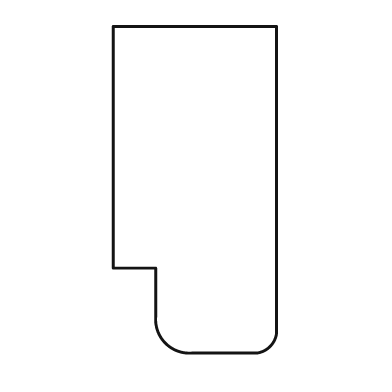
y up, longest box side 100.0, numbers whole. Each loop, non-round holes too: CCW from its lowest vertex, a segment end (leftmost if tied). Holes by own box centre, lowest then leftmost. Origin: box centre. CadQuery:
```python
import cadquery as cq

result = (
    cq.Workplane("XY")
    .moveTo(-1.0, -50.0)
    .lineTo(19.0, -50.0)
    .threePointArc((23.0, -48.0), (25.0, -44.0))
    .lineTo(25.0, 50.0)
    .lineTo(-25.0, 50.0)
    .lineTo(-25.0, -24.0)
    .lineTo(-12.0, -24.0)
    .lineTo(-12.0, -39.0)
    .threePointArc((-9.0, -47.0), (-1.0, -50.0))
    .close()
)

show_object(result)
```